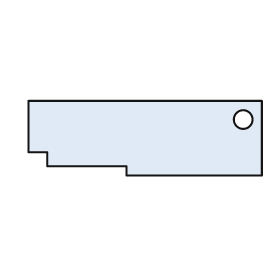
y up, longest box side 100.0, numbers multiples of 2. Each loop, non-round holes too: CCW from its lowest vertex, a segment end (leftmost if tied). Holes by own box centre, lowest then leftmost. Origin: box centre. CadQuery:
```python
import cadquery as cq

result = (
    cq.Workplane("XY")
    .moveTo(-8.0, -16.0)
    .lineTo(50.0, -16.0)
    .lineTo(50.0, 16.0)
    .lineTo(-50.0, 16.0)
    .lineTo(-50.0, -6.0)
    .lineTo(-42.0, -6.0)
    .lineTo(-42.0, -12.0)
    .lineTo(-8.0, -12.0)
    .close()
    .moveTo(42.0, 8.0)
    .circle(4.0)
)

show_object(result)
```